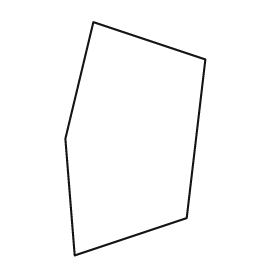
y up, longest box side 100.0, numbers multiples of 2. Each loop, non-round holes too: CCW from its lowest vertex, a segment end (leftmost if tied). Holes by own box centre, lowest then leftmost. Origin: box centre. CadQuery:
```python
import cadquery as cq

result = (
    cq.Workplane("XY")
    .moveTo(-26.0, -50.0)
    .lineTo(22.0, -34.0)
    .lineTo(30.0, 34.0)
    .lineTo(-18.0, 50.0)
    .lineTo(-30.0, 0.0)
    .close()
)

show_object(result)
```